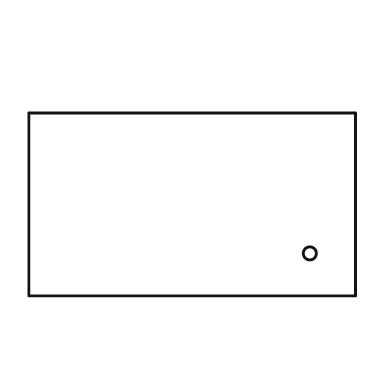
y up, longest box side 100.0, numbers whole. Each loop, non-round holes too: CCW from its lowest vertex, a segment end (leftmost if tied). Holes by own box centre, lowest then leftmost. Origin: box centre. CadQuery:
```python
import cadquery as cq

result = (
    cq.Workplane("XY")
    .moveTo(-50.0, -28.0)
    .lineTo(50.0, -28.0)
    .lineTo(50.0, 28.0)
    .lineTo(-50.0, 28.0)
    .close()
    .moveTo(36.0, -15.0)
    .circle(2.0)
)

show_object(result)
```